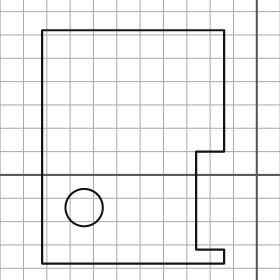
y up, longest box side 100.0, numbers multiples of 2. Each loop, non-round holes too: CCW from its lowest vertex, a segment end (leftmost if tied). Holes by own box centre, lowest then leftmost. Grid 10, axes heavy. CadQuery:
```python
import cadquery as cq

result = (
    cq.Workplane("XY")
    .moveTo(-92.0, -38.0)
    .lineTo(-14.0, -38.0)
    .lineTo(-14.0, -32.0)
    .lineTo(-26.0, -32.0)
    .lineTo(-26.0, 10.0)
    .lineTo(-14.0, 10.0)
    .lineTo(-14.0, 62.0)
    .lineTo(-92.0, 62.0)
    .close()
    .moveTo(-74.0, -14.0)
    .circle(8.0)
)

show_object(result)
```